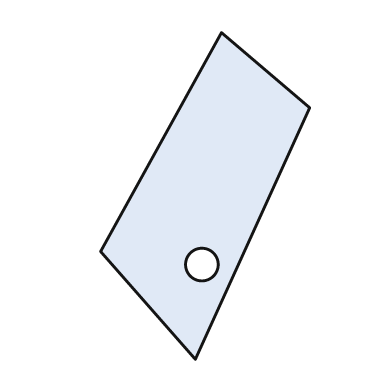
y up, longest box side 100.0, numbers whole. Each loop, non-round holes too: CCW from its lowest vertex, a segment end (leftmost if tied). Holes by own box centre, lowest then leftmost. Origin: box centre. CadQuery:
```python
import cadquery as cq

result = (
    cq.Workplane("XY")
    .moveTo(-3.0, -50.0)
    .lineTo(32.0, 27.0)
    .lineTo(5.0, 50.0)
    .lineTo(-32.0, -17.0)
    .close()
    .moveTo(-1.0, -21.0)
    .circle(5.0)
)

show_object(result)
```